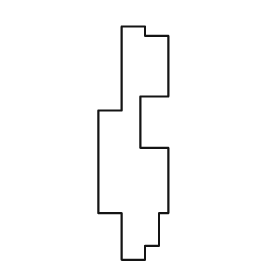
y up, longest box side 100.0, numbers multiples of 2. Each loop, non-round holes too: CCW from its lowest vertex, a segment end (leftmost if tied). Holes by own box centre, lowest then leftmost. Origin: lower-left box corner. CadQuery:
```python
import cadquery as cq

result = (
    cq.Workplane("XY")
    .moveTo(10.0, 0.0)
    .lineTo(20.0, 0.0)
    .lineTo(20.0, 6.0)
    .lineTo(26.0, 6.0)
    .lineTo(26.0, 20.0)
    .lineTo(30.0, 20.0)
    .lineTo(30.0, 48.0)
    .lineTo(18.0, 48.0)
    .lineTo(18.0, 70.0)
    .lineTo(30.0, 70.0)
    .lineTo(30.0, 96.0)
    .lineTo(20.0, 96.0)
    .lineTo(20.0, 100.0)
    .lineTo(10.0, 100.0)
    .lineTo(10.0, 64.0)
    .lineTo(0.0, 64.0)
    .lineTo(0.0, 20.0)
    .lineTo(10.0, 20.0)
    .close()
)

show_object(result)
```